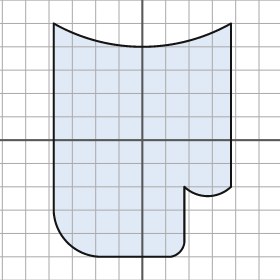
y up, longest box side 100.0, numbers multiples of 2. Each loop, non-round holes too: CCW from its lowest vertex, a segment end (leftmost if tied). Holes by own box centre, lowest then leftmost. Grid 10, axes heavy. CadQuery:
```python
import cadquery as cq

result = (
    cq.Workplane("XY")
    .moveTo(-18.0, -50.0)
    .lineTo(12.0, -50.0)
    .threePointArc((16.0, -48.0), (18.0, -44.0))
    .lineTo(18.0, -20.0)
    .threePointArc((28.0, -24.0), (38.0, -20.0))
    .lineTo(38.0, 50.0)
    .threePointArc((0.0, 40.0), (-38.0, 50.0))
    .lineTo(-38.0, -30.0)
    .threePointArc((-32.0, -44.0), (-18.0, -50.0))
    .close()
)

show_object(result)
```